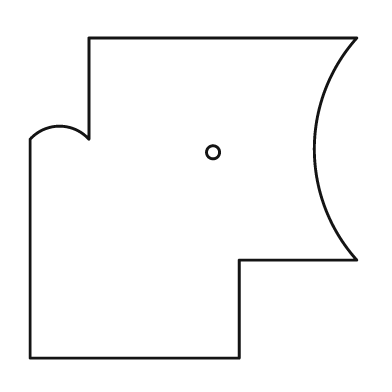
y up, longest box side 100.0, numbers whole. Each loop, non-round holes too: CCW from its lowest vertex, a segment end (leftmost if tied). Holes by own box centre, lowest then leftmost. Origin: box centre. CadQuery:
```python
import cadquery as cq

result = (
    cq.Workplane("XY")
    .moveTo(-50.0, -49.0)
    .lineTo(14.0, -49.0)
    .lineTo(14.0, -19.0)
    .lineTo(50.0, -19.0)
    .threePointArc((37.0, 15.0), (50.0, 49.0))
    .lineTo(-32.0, 49.0)
    .lineTo(-32.0, 18.0)
    .threePointArc((-41.0, 22.0), (-50.0, 18.0))
    .close()
    .moveTo(6.0, 14.0)
    .circle(2.0)
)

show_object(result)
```